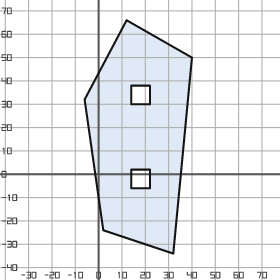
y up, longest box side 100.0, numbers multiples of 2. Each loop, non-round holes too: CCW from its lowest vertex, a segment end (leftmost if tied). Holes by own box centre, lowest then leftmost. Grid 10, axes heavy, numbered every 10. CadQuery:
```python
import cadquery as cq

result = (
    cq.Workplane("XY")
    .moveTo(32.0, -34.0)
    .lineTo(40.0, 50.0)
    .lineTo(12.0, 66.0)
    .lineTo(-6.0, 32.0)
    .lineTo(2.0, -24.0)
    .close()
    .moveTo(14.0, -6.0)
    .lineTo(22.0, -6.0)
    .lineTo(22.0, 2.0)
    .lineTo(14.0, 2.0)
    .close()
    .moveTo(14.0, 30.0)
    .lineTo(22.0, 30.0)
    .lineTo(22.0, 38.0)
    .lineTo(14.0, 38.0)
    .close()
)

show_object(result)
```